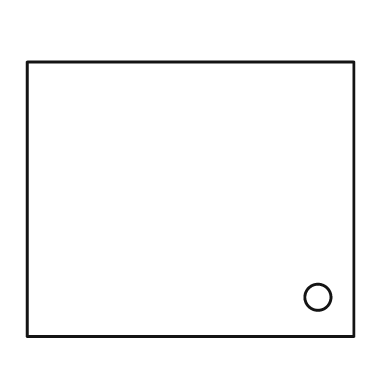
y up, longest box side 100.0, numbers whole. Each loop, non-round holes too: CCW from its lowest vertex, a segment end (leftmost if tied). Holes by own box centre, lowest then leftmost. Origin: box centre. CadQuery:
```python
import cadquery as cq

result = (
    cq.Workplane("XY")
    .moveTo(-50.0, -42.0)
    .lineTo(50.0, -42.0)
    .lineTo(50.0, 42.0)
    .lineTo(-50.0, 42.0)
    .close()
    .moveTo(39.0, -30.0)
    .circle(4.0)
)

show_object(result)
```